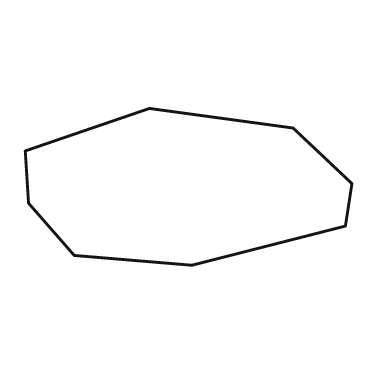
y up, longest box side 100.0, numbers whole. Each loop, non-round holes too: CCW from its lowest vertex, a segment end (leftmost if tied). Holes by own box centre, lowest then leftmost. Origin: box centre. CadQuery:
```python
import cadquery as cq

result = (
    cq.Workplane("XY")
    .moveTo(1.0, -24.0)
    .lineTo(48.0, -12.0)
    .lineTo(50.0, 1.0)
    .lineTo(32.0, 18.0)
    .lineTo(-12.0, 24.0)
    .lineTo(-50.0, 11.0)
    .lineTo(-49.0, -5.0)
    .lineTo(-35.0, -21.0)
    .close()
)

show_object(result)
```